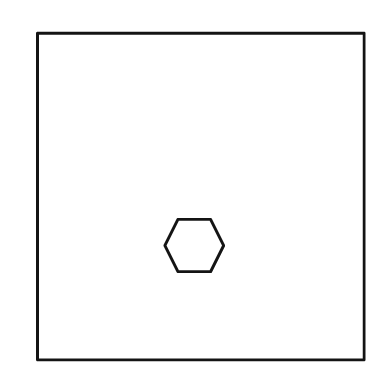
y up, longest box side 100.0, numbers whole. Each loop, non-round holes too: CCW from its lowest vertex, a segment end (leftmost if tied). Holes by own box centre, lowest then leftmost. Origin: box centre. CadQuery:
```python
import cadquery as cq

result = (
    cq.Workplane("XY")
    .moveTo(-50.0, -50.0)
    .lineTo(50.0, -50.0)
    .lineTo(50.0, 50.0)
    .lineTo(-50.0, 50.0)
    .close()
    .moveTo(-7.0, -23.0)
    .lineTo(3.0, -23.0)
    .lineTo(7.0, -15.0)
    .lineTo(3.0, -7.0)
    .lineTo(-7.0, -7.0)
    .lineTo(-11.0, -15.0)
    .close()
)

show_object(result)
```